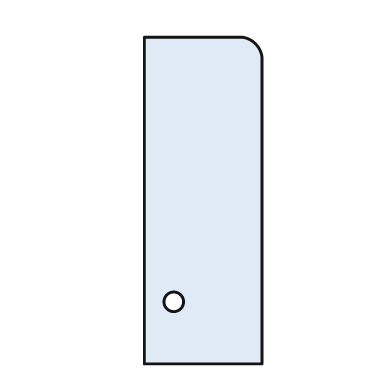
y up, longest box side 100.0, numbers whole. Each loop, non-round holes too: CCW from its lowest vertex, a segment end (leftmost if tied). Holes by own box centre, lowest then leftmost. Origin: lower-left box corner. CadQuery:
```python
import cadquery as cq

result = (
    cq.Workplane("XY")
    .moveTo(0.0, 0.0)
    .lineTo(36.0, 0.0)
    .lineTo(36.0, 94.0)
    .threePointArc((34.0, 98.0), (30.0, 100.0))
    .lineTo(0.0, 100.0)
    .close()
    .moveTo(9.0, 19.0)
    .circle(3.0)
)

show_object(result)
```